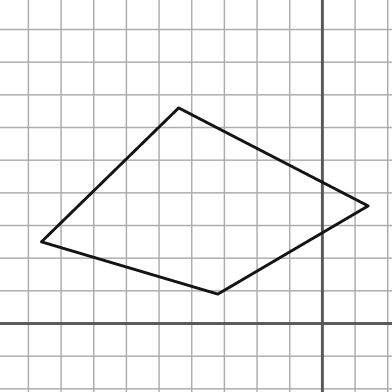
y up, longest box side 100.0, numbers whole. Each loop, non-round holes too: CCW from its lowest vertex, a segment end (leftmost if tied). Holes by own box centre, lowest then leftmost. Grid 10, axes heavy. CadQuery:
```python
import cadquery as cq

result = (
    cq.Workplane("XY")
    .moveTo(-32.0, 9.0)
    .lineTo(14.0, 36.0)
    .lineTo(-44.0, 66.0)
    .lineTo(-86.0, 25.0)
    .close()
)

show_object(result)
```